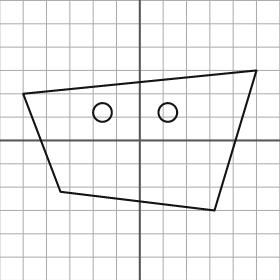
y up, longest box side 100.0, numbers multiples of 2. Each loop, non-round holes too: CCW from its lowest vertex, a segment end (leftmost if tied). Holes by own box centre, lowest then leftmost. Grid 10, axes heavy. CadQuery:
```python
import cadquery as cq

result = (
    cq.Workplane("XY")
    .moveTo(32.0, -30.0)
    .lineTo(50.0, 30.0)
    .lineTo(-50.0, 20.0)
    .lineTo(-34.0, -22.0)
    .close()
    .moveTo(-16.0, 12.0)
    .circle(4.0)
    .moveTo(12.0, 12.0)
    .circle(4.0)
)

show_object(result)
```